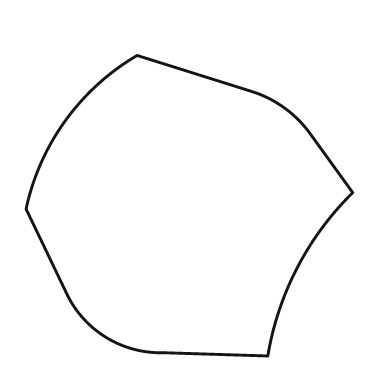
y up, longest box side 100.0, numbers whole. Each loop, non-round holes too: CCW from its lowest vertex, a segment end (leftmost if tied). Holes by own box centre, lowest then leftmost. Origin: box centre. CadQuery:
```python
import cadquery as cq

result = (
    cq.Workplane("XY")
    .moveTo(24.0, -46.0)
    .threePointArc((33.0, -19.0), (50.0, 4.0))
    .lineTo(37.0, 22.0)
    .threePointArc((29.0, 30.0), (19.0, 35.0))
    .lineTo(-16.0, 46.0)
    .threePointArc((-38.0, 26.0), (-50.0, -1.0))
    .lineTo(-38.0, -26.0)
    .threePointArc((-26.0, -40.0), (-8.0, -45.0))
    .close()
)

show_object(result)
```